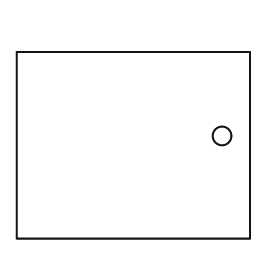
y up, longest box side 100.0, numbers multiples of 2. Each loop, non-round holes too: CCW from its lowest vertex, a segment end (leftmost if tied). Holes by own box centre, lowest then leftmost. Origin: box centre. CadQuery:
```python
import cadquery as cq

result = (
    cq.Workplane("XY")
    .moveTo(-50.0, -40.0)
    .lineTo(50.0, -40.0)
    .lineTo(50.0, 40.0)
    .lineTo(-50.0, 40.0)
    .close()
    .moveTo(38.0, 4.0)
    .circle(4.0)
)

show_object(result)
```